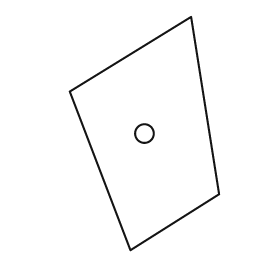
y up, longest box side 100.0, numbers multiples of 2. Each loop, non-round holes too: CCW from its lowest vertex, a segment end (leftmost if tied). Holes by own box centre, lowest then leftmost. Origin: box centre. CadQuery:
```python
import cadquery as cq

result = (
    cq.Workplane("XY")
    .moveTo(-6.0, -50.0)
    .lineTo(32.0, -26.0)
    .lineTo(20.0, 50.0)
    .lineTo(-32.0, 18.0)
    .close()
    .moveTo(0.0, 0.0)
    .circle(4.0)
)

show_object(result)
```